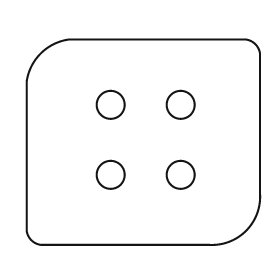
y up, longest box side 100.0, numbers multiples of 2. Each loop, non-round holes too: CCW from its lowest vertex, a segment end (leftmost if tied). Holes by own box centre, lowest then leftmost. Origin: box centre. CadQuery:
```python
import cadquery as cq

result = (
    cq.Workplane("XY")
    .moveTo(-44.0, -44.0)
    .lineTo(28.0, -44.0)
    .threePointArc((44.0, -38.0), (50.0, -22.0))
    .lineTo(50.0, 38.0)
    .threePointArc((48.0, 42.0), (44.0, 44.0))
    .lineTo(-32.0, 44.0)
    .threePointArc((-44.0, 38.0), (-50.0, 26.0))
    .lineTo(-50.0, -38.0)
    .threePointArc((-48.0, -42.0), (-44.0, -44.0))
    .close()
    .moveTo(-14.0, -14.0)
    .circle(6.0)
    .moveTo(16.0, -14.0)
    .circle(6.0)
    .moveTo(-14.0, 16.0)
    .circle(6.0)
    .moveTo(16.0, 16.0)
    .circle(6.0)
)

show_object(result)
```